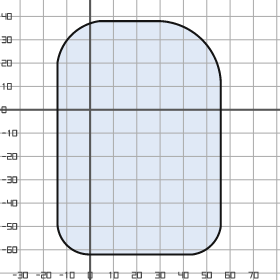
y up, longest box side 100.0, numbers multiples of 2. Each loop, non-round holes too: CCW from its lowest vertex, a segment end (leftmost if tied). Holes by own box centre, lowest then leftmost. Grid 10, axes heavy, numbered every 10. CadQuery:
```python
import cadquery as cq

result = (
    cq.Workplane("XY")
    .moveTo(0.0, -62.0)
    .lineTo(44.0, -62.0)
    .threePointArc((52.0, -58.0), (56.0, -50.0))
    .lineTo(56.0, 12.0)
    .threePointArc((48.0, 30.0), (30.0, 38.0))
    .lineTo(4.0, 38.0)
    .threePointArc((-8.0, 32.0), (-14.0, 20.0))
    .lineTo(-14.0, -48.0)
    .threePointArc((-10.0, -58.0), (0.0, -62.0))
    .close()
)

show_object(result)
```